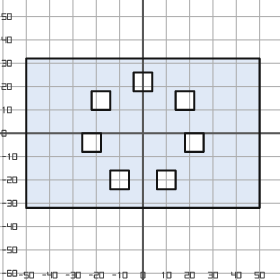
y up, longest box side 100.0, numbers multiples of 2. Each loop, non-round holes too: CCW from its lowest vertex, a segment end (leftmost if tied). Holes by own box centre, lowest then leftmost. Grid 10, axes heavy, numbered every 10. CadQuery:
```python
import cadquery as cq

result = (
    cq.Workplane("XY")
    .moveTo(-50.0, -32.0)
    .lineTo(50.0, -32.0)
    .lineTo(50.0, 32.0)
    .lineTo(-50.0, 32.0)
    .close()
    .moveTo(-14.0, -24.0)
    .lineTo(-6.0, -24.0)
    .lineTo(-6.0, -16.0)
    .lineTo(-14.0, -16.0)
    .close()
    .moveTo(6.0, -24.0)
    .lineTo(14.0, -24.0)
    .lineTo(14.0, -16.0)
    .lineTo(6.0, -16.0)
    .close()
    .moveTo(-26.0, -8.0)
    .lineTo(-18.0, -8.0)
    .lineTo(-18.0, 0.0)
    .lineTo(-26.0, 0.0)
    .close()
    .moveTo(18.0, -8.0)
    .lineTo(26.0, -8.0)
    .lineTo(26.0, 0.0)
    .lineTo(18.0, 0.0)
    .close()
    .moveTo(-22.0, 10.0)
    .lineTo(-14.0, 10.0)
    .lineTo(-14.0, 18.0)
    .lineTo(-22.0, 18.0)
    .close()
    .moveTo(14.0, 10.0)
    .lineTo(22.0, 10.0)
    .lineTo(22.0, 18.0)
    .lineTo(14.0, 18.0)
    .close()
    .moveTo(-4.0, 18.0)
    .lineTo(4.0, 18.0)
    .lineTo(4.0, 26.0)
    .lineTo(-4.0, 26.0)
    .close()
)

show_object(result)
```